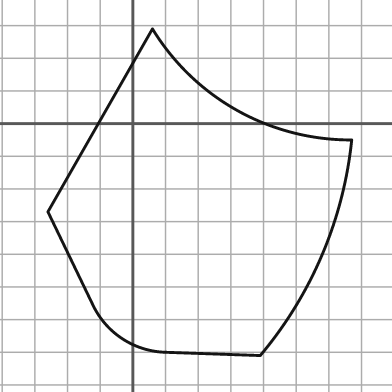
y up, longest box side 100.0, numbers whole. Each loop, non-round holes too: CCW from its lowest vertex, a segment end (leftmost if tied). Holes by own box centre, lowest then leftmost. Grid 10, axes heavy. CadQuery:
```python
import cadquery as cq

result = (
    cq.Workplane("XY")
    .moveTo(39.0, -71.0)
    .threePointArc((58.0, -40.0), (67.0, -5.0))
    .threePointArc((32.0, 4.0), (6.0, 29.0))
    .lineTo(-26.0, -27.0)
    .lineTo(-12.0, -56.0)
    .threePointArc((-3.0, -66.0), (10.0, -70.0))
    .close()
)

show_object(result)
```